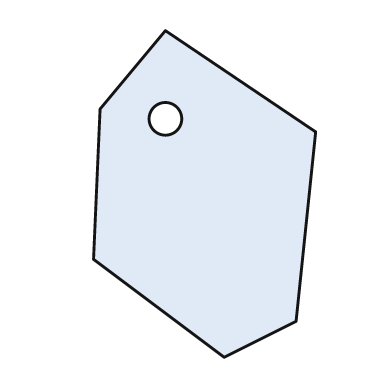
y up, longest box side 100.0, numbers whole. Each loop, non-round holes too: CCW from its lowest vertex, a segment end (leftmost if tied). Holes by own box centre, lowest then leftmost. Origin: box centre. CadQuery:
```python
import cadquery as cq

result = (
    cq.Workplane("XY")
    .moveTo(6.0, -50.0)
    .lineTo(28.0, -39.0)
    .lineTo(34.0, 19.0)
    .lineTo(-12.0, 50.0)
    .lineTo(-32.0, 26.0)
    .lineTo(-34.0, -20.0)
    .close()
    .moveTo(-12.0, 23.0)
    .circle(5.0)
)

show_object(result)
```